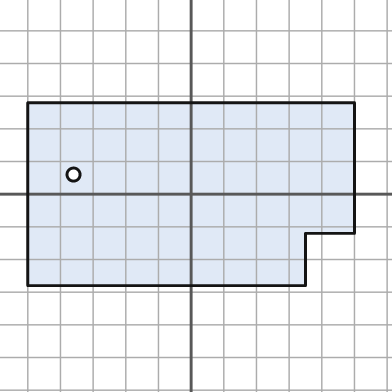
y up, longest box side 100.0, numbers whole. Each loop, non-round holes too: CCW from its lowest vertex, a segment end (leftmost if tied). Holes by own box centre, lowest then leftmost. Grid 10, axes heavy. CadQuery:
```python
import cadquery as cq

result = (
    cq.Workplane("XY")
    .moveTo(-50.0, -28.0)
    .lineTo(35.0, -28.0)
    .lineTo(35.0, -12.0)
    .lineTo(50.0, -12.0)
    .lineTo(50.0, 28.0)
    .lineTo(-50.0, 28.0)
    .close()
    .moveTo(-36.0, 6.0)
    .circle(2.0)
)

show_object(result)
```